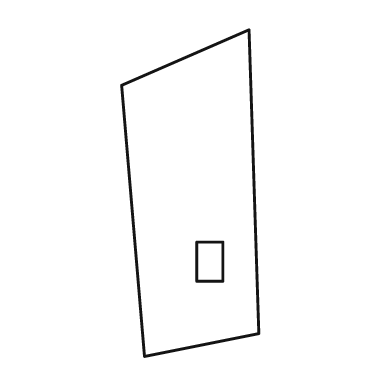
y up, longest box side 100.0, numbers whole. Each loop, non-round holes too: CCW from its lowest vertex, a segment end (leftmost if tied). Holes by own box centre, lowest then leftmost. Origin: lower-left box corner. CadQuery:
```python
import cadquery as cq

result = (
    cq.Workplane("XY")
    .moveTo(7.0, 0.0)
    .lineTo(42.0, 7.0)
    .lineTo(39.0, 100.0)
    .lineTo(0.0, 83.0)
    .close()
    .moveTo(23.0, 23.0)
    .lineTo(31.0, 23.0)
    .lineTo(31.0, 35.0)
    .lineTo(23.0, 35.0)
    .close()
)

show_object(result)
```